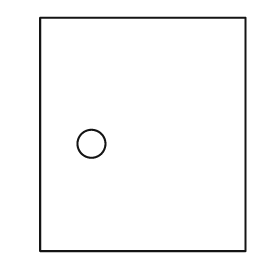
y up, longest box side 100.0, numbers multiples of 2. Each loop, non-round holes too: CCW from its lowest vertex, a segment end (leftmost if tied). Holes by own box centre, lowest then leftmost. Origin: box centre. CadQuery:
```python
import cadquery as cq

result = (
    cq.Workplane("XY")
    .moveTo(-44.0, -50.0)
    .lineTo(44.0, -50.0)
    .lineTo(44.0, 50.0)
    .lineTo(-44.0, 50.0)
    .close()
    .moveTo(-22.0, -4.0)
    .circle(6.0)
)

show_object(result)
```